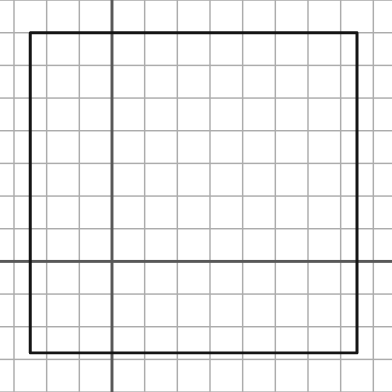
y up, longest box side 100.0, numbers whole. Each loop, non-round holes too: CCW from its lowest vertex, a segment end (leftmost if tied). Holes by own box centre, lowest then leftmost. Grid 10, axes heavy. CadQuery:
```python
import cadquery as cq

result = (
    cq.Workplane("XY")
    .moveTo(-25.0, -28.0)
    .lineTo(75.0, -28.0)
    .lineTo(75.0, 70.0)
    .lineTo(-25.0, 70.0)
    .close()
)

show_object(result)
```